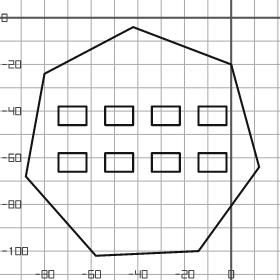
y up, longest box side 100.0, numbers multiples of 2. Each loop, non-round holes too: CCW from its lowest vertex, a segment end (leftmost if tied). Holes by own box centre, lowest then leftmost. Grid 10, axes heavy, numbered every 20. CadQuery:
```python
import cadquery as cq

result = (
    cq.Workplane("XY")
    .moveTo(-58.0, -102.0)
    .lineTo(-14.0, -100.0)
    .lineTo(12.0, -64.0)
    .lineTo(0.0, -20.0)
    .lineTo(-42.0, -4.0)
    .lineTo(-80.0, -24.0)
    .lineTo(-88.0, -68.0)
    .close()
    .moveTo(-74.0, -66.0)
    .lineTo(-62.0, -66.0)
    .lineTo(-62.0, -58.0)
    .lineTo(-74.0, -58.0)
    .close()
    .moveTo(-54.0, -66.0)
    .lineTo(-42.0, -66.0)
    .lineTo(-42.0, -58.0)
    .lineTo(-54.0, -58.0)
    .close()
    .moveTo(-34.0, -66.0)
    .lineTo(-22.0, -66.0)
    .lineTo(-22.0, -58.0)
    .lineTo(-34.0, -58.0)
    .close()
    .moveTo(-14.0, -66.0)
    .lineTo(-2.0, -66.0)
    .lineTo(-2.0, -58.0)
    .lineTo(-14.0, -58.0)
    .close()
    .moveTo(-74.0, -46.0)
    .lineTo(-62.0, -46.0)
    .lineTo(-62.0, -38.0)
    .lineTo(-74.0, -38.0)
    .close()
    .moveTo(-54.0, -46.0)
    .lineTo(-42.0, -46.0)
    .lineTo(-42.0, -38.0)
    .lineTo(-54.0, -38.0)
    .close()
    .moveTo(-34.0, -46.0)
    .lineTo(-22.0, -46.0)
    .lineTo(-22.0, -38.0)
    .lineTo(-34.0, -38.0)
    .close()
    .moveTo(-14.0, -46.0)
    .lineTo(-2.0, -46.0)
    .lineTo(-2.0, -38.0)
    .lineTo(-14.0, -38.0)
    .close()
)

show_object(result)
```